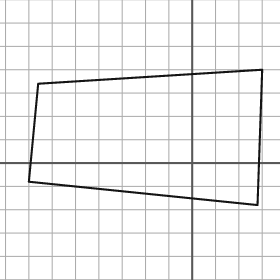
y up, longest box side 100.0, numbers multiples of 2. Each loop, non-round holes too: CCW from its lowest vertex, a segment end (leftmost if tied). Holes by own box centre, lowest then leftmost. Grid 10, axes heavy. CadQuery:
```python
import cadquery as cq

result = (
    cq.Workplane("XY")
    .moveTo(28.0, -18.0)
    .lineTo(30.0, 40.0)
    .lineTo(-66.0, 34.0)
    .lineTo(-70.0, -8.0)
    .close()
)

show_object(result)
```